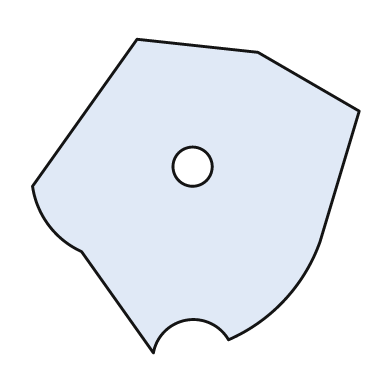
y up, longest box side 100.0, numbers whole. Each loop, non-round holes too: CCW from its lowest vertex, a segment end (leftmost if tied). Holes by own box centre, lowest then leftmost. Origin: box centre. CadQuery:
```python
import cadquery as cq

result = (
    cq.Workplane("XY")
    .moveTo(-13.0, -48.0)
    .threePointArc((-3.0, -38.0), (10.0, -44.0))
    .threePointArc((27.0, -32.0), (38.0, -14.0))
    .lineTo(50.0, 26.0)
    .lineTo(19.0, 44.0)
    .lineTo(-18.0, 48.0)
    .lineTo(-50.0, 3.0)
    .threePointArc((-45.0, -9.0), (-35.0, -17.0))
    .close()
    .moveTo(-1.0, 9.0)
    .circle(6.0)
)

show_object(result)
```